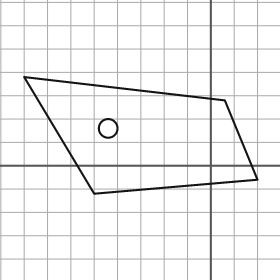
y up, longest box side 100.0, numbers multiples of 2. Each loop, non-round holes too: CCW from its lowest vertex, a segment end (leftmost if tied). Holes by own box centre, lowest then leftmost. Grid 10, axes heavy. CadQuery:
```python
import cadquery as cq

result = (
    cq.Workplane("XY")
    .moveTo(-50.0, -12.0)
    .lineTo(20.0, -6.0)
    .lineTo(6.0, 28.0)
    .lineTo(-80.0, 38.0)
    .close()
    .moveTo(-44.0, 16.0)
    .circle(4.0)
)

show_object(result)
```